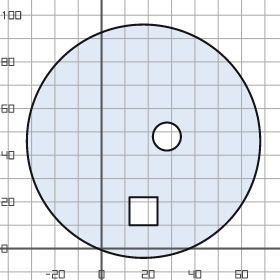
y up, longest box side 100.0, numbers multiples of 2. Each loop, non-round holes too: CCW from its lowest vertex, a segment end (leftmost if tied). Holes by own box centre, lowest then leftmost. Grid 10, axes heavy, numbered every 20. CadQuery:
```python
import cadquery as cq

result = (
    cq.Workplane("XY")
    .moveTo(18.0, 46.0)
    .circle(50.0)
    .moveTo(12.0, 10.0)
    .lineTo(24.0, 10.0)
    .lineTo(24.0, 22.0)
    .lineTo(12.0, 22.0)
    .close()
    .moveTo(28.0, 48.0)
    .circle(6.0)
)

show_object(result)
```